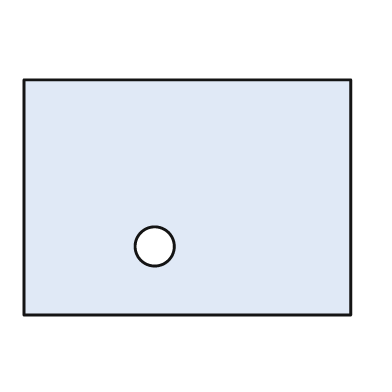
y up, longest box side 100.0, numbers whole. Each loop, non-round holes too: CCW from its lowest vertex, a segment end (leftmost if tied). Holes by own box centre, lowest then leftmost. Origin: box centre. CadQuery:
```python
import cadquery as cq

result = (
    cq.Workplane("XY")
    .moveTo(-50.0, -36.0)
    .lineTo(50.0, -36.0)
    .lineTo(50.0, 36.0)
    .lineTo(-50.0, 36.0)
    .close()
    .moveTo(-10.0, -15.0)
    .circle(6.0)
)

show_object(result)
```